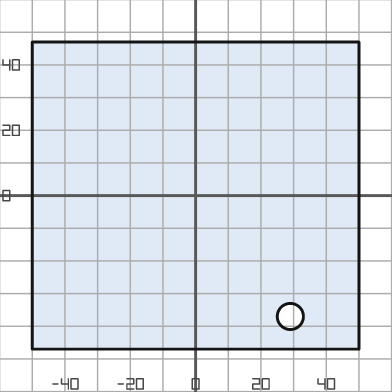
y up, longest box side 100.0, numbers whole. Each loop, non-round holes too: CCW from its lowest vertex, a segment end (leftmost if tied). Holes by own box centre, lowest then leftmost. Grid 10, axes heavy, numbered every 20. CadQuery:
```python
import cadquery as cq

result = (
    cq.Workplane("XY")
    .moveTo(-50.0, -47.0)
    .lineTo(50.0, -47.0)
    .lineTo(50.0, 47.0)
    .lineTo(-50.0, 47.0)
    .close()
    .moveTo(29.0, -37.0)
    .circle(4.0)
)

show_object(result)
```